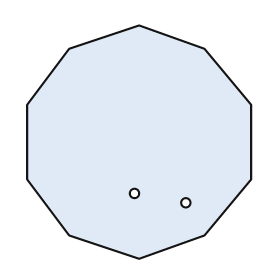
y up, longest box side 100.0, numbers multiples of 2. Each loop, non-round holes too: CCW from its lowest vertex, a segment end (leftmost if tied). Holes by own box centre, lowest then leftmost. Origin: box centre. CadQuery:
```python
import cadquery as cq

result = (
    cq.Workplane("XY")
    .moveTo(0.0, -50.0)
    .lineTo(28.0, -40.0)
    .lineTo(48.0, -16.0)
    .lineTo(48.0, 16.0)
    .lineTo(28.0, 40.0)
    .lineTo(0.0, 50.0)
    .lineTo(-30.0, 40.0)
    .lineTo(-48.0, 16.0)
    .lineTo(-48.0, -16.0)
    .lineTo(-30.0, -40.0)
    .close()
    .moveTo(20.0, -26.0)
    .circle(2.0)
    .moveTo(-2.0, -22.0)
    .circle(2.0)
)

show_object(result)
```